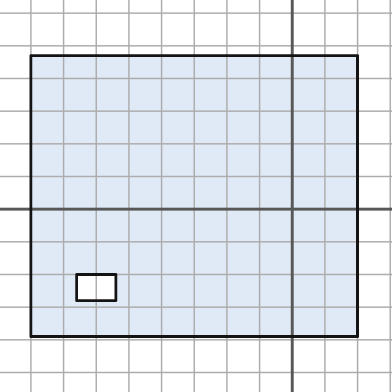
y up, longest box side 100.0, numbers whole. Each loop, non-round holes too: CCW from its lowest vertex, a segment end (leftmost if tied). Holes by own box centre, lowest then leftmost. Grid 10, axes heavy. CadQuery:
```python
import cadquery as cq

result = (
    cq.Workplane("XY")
    .moveTo(-80.0, -39.0)
    .lineTo(20.0, -39.0)
    .lineTo(20.0, 47.0)
    .lineTo(-80.0, 47.0)
    .close()
    .moveTo(-66.0, -28.0)
    .lineTo(-54.0, -28.0)
    .lineTo(-54.0, -20.0)
    .lineTo(-66.0, -20.0)
    .close()
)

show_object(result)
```